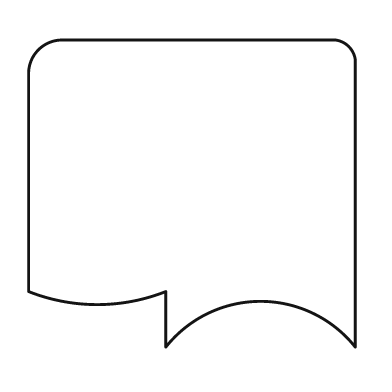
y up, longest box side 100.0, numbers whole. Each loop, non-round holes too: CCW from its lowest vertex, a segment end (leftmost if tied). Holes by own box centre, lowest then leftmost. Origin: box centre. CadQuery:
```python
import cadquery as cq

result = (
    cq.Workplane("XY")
    .moveTo(-8.0, -47.0)
    .threePointArc((21.0, -33.0), (50.0, -47.0))
    .lineTo(50.0, 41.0)
    .threePointArc((48.0, 45.0), (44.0, 47.0))
    .lineTo(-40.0, 47.0)
    .threePointArc((-47.0, 44.0), (-50.0, 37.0))
    .lineTo(-50.0, -30.0)
    .threePointArc((-29.0, -34.0), (-8.0, -30.0))
    .close()
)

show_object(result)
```